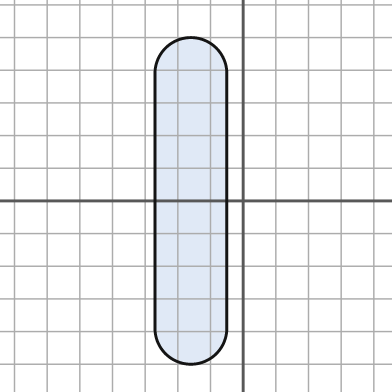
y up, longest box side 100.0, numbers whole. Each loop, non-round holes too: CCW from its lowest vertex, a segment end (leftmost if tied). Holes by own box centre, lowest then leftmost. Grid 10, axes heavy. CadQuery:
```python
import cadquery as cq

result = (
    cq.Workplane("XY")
    .moveTo(-27.0, -39.0)
    .threePointArc((-16.0, -50.0), (-5.0, -39.0))
    .lineTo(-5.0, 39.0)
    .threePointArc((-16.0, 50.0), (-27.0, 39.0))
    .close()
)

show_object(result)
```